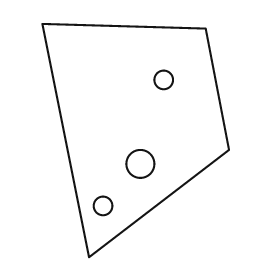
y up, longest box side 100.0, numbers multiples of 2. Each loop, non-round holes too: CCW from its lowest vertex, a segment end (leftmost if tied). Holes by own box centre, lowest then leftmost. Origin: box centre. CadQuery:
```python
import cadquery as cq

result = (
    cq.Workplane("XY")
    .moveTo(-20.0, -50.0)
    .lineTo(40.0, -4.0)
    .lineTo(30.0, 48.0)
    .lineTo(-40.0, 50.0)
    .close()
    .moveTo(-14.0, -28.0)
    .circle(4.0)
    .moveTo(2.0, -10.0)
    .circle(6.0)
    .moveTo(12.0, 26.0)
    .circle(4.0)
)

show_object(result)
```